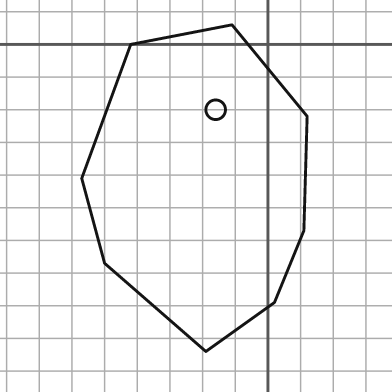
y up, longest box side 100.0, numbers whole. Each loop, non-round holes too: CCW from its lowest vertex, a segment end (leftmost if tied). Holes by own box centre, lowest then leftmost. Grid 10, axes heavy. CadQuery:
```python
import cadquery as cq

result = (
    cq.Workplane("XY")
    .moveTo(-19.0, -94.0)
    .lineTo(2.0, -79.0)
    .lineTo(11.0, -57.0)
    .lineTo(12.0, -22.0)
    .lineTo(-11.0, 6.0)
    .lineTo(-42.0, 0.0)
    .lineTo(-57.0, -41.0)
    .lineTo(-50.0, -67.0)
    .close()
    .moveTo(-16.0, -20.0)
    .circle(3.0)
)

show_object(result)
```